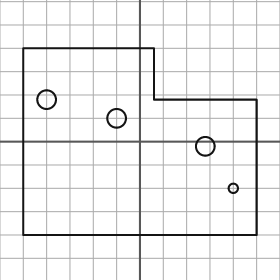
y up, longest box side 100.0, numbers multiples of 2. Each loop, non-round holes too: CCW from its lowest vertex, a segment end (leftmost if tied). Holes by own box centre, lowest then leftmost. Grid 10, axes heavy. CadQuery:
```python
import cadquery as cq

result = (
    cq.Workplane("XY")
    .moveTo(-50.0, -40.0)
    .lineTo(50.0, -40.0)
    .lineTo(50.0, 18.0)
    .lineTo(6.0, 18.0)
    .lineTo(6.0, 40.0)
    .lineTo(-50.0, 40.0)
    .close()
    .moveTo(40.0, -20.0)
    .circle(2.0)
    .moveTo(28.0, -2.0)
    .circle(4.0)
    .moveTo(-10.0, 10.0)
    .circle(4.0)
    .moveTo(-40.0, 18.0)
    .circle(4.0)
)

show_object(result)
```